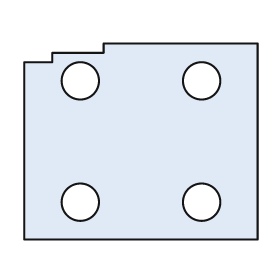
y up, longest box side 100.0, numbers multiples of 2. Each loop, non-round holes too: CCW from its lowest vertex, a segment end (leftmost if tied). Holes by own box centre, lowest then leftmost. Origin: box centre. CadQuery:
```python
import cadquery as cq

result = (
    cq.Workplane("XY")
    .moveTo(-50.0, -42.0)
    .lineTo(50.0, -42.0)
    .lineTo(50.0, 42.0)
    .lineTo(-16.0, 42.0)
    .lineTo(-16.0, 38.0)
    .lineTo(-38.0, 38.0)
    .lineTo(-38.0, 34.0)
    .lineTo(-50.0, 34.0)
    .close()
    .moveTo(-26.0, -26.0)
    .circle(8.0)
    .moveTo(26.0, -26.0)
    .circle(8.0)
    .moveTo(-26.0, 26.0)
    .circle(8.0)
    .moveTo(26.0, 26.0)
    .circle(8.0)
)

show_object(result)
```